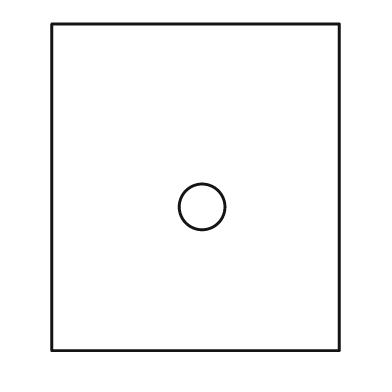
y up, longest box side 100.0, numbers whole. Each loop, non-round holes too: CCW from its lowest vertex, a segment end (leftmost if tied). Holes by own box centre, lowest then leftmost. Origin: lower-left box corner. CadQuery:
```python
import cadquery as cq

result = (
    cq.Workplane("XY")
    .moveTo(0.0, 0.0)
    .lineTo(88.0, 0.0)
    .lineTo(88.0, 100.0)
    .lineTo(0.0, 100.0)
    .close()
    .moveTo(46.0, 44.0)
    .circle(7.0)
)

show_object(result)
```